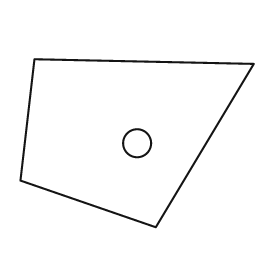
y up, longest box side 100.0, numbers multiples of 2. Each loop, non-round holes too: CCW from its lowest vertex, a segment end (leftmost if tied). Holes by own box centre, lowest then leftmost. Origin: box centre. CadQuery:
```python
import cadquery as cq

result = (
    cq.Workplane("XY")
    .moveTo(8.0, -36.0)
    .lineTo(50.0, 34.0)
    .lineTo(-44.0, 36.0)
    .lineTo(-50.0, -16.0)
    .close()
    .moveTo(0.0, 0.0)
    .circle(6.0)
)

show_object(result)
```